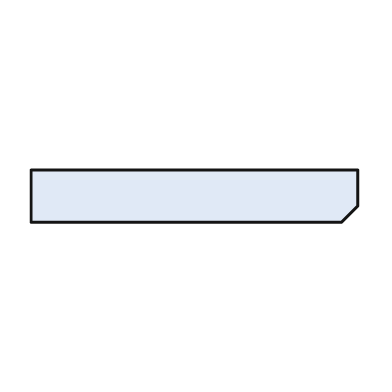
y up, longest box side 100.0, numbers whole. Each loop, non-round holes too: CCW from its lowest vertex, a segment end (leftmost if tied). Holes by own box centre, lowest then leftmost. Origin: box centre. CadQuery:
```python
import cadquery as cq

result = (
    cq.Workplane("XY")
    .moveTo(-50.0, -8.0)
    .lineTo(45.0, -8.0)
    .lineTo(50.0, -3.0)
    .lineTo(50.0, 8.0)
    .lineTo(-50.0, 8.0)
    .close()
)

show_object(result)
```